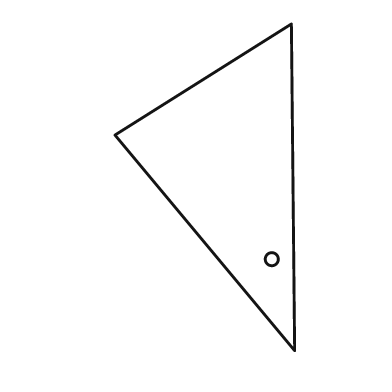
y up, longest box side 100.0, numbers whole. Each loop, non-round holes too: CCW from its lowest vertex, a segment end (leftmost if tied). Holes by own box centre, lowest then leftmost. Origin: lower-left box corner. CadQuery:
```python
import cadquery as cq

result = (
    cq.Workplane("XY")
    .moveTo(55.0, 0.0)
    .lineTo(54.0, 100.0)
    .lineTo(0.0, 66.0)
    .close()
    .moveTo(48.0, 28.0)
    .circle(2.0)
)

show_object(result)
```